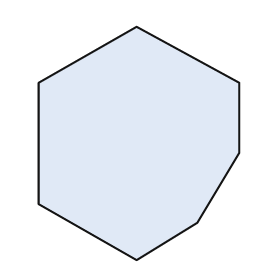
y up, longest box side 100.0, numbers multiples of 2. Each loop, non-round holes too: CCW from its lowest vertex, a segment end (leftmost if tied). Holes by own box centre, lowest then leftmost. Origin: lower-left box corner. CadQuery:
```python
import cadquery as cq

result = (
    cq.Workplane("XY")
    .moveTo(42.0, 0.0)
    .lineTo(68.0, 16.0)
    .lineTo(86.0, 46.0)
    .lineTo(86.0, 76.0)
    .lineTo(42.0, 100.0)
    .lineTo(0.0, 76.0)
    .lineTo(0.0, 24.0)
    .close()
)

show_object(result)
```